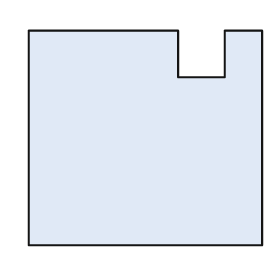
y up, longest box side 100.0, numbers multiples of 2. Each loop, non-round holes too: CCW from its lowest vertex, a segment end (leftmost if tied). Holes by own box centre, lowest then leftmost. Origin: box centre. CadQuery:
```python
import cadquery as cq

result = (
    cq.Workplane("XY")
    .moveTo(-50.0, -46.0)
    .lineTo(50.0, -46.0)
    .lineTo(50.0, 46.0)
    .lineTo(34.0, 46.0)
    .lineTo(34.0, 26.0)
    .lineTo(14.0, 26.0)
    .lineTo(14.0, 46.0)
    .lineTo(-50.0, 46.0)
    .close()
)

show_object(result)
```